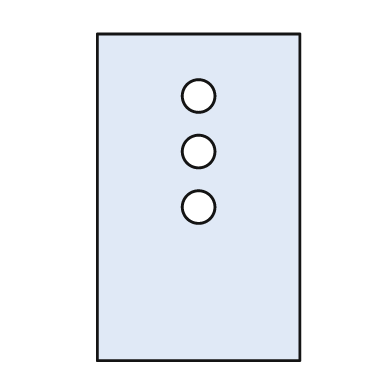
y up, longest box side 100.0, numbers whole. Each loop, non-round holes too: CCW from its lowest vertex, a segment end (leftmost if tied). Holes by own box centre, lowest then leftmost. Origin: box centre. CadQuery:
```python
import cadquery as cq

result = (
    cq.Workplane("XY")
    .moveTo(-31.0, -50.0)
    .lineTo(31.0, -50.0)
    .lineTo(31.0, 50.0)
    .lineTo(-31.0, 50.0)
    .close()
    .moveTo(0.0, -3.0)
    .circle(5.0)
    .moveTo(0.0, 14.0)
    .circle(5.0)
    .moveTo(0.0, 31.0)
    .circle(5.0)
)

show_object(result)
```